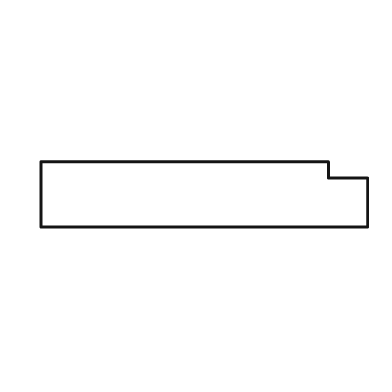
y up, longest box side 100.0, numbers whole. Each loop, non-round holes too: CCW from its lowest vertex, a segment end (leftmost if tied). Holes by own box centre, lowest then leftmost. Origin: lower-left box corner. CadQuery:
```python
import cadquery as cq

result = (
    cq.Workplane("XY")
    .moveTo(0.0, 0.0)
    .lineTo(100.0, 0.0)
    .lineTo(100.0, 15.0)
    .lineTo(88.0, 15.0)
    .lineTo(88.0, 20.0)
    .lineTo(0.0, 20.0)
    .close()
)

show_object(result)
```